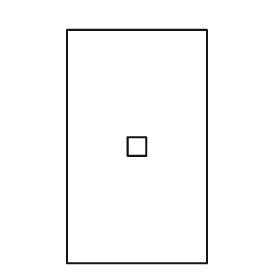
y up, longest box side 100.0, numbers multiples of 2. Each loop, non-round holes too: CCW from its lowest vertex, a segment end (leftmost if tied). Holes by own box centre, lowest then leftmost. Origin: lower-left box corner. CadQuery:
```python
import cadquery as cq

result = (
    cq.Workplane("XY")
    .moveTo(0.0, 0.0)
    .lineTo(60.0, 0.0)
    .lineTo(60.0, 100.0)
    .lineTo(0.0, 100.0)
    .close()
    .moveTo(26.0, 46.0)
    .lineTo(34.0, 46.0)
    .lineTo(34.0, 54.0)
    .lineTo(26.0, 54.0)
    .close()
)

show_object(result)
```